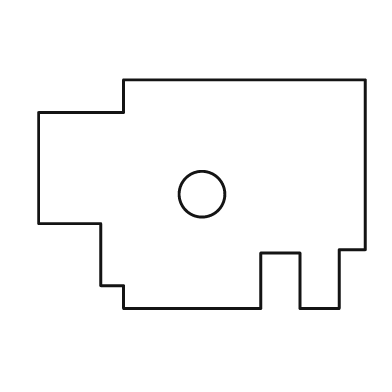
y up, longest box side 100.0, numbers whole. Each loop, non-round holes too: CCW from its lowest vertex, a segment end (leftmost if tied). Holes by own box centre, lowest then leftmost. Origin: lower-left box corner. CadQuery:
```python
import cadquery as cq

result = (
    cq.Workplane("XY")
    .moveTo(26.0, 0.0)
    .lineTo(68.0, 0.0)
    .lineTo(68.0, 17.0)
    .lineTo(80.0, 17.0)
    .lineTo(80.0, 0.0)
    .lineTo(92.0, 0.0)
    .lineTo(92.0, 18.0)
    .lineTo(100.0, 18.0)
    .lineTo(100.0, 70.0)
    .lineTo(26.0, 70.0)
    .lineTo(26.0, 60.0)
    .lineTo(0.0, 60.0)
    .lineTo(0.0, 26.0)
    .lineTo(19.0, 26.0)
    .lineTo(19.0, 7.0)
    .lineTo(26.0, 7.0)
    .close()
    .moveTo(50.0, 35.0)
    .circle(7.0)
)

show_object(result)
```